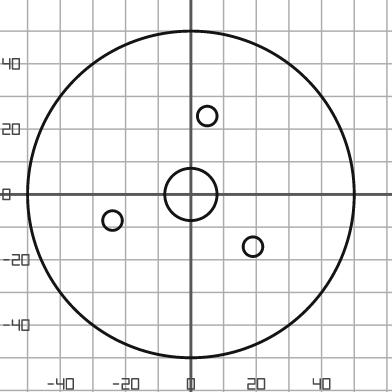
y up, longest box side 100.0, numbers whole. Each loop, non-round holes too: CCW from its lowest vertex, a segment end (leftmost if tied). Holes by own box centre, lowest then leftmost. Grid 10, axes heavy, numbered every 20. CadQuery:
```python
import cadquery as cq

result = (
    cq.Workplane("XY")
    .moveTo(0.0, 0.0)
    .circle(50.0)
    .moveTo(19.0, -16.0)
    .circle(3.0)
    .moveTo(-24.0, -8.0)
    .circle(3.0)
    .moveTo(0.0, 0.0)
    .circle(8.0)
    .moveTo(5.0, 24.0)
    .circle(3.0)
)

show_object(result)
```